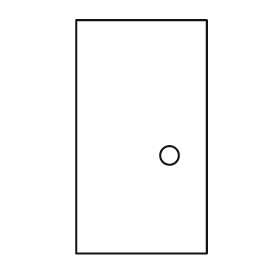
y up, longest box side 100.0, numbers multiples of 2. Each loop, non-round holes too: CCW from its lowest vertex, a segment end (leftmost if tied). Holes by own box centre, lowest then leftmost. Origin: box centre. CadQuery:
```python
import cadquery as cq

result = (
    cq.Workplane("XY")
    .moveTo(-28.0, -50.0)
    .lineTo(28.0, -50.0)
    .lineTo(28.0, 50.0)
    .lineTo(-28.0, 50.0)
    .close()
    .moveTo(12.0, -8.0)
    .circle(4.0)
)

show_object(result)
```